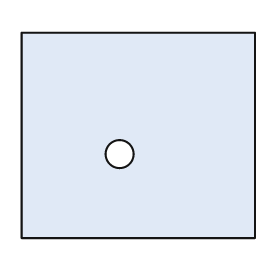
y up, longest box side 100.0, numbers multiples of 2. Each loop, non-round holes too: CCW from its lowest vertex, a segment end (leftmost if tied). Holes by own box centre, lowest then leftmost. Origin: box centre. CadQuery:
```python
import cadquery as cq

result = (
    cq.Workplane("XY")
    .moveTo(-50.0, -44.0)
    .lineTo(50.0, -44.0)
    .lineTo(50.0, 44.0)
    .lineTo(-50.0, 44.0)
    .close()
    .moveTo(-8.0, -8.0)
    .circle(6.0)
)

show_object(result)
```